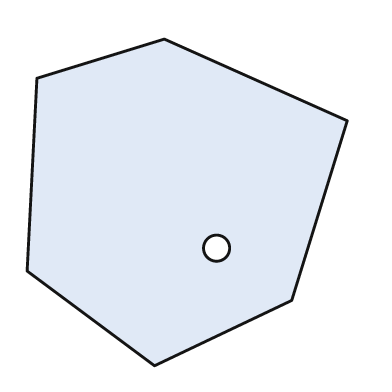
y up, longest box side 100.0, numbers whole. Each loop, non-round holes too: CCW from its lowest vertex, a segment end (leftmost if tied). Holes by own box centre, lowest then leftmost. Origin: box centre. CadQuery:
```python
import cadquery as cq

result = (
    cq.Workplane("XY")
    .moveTo(-10.0, -50.0)
    .lineTo(32.0, -30.0)
    .lineTo(49.0, 25.0)
    .lineTo(-7.0, 50.0)
    .lineTo(-46.0, 38.0)
    .lineTo(-49.0, -21.0)
    .close()
    .moveTo(9.0, -14.0)
    .circle(4.0)
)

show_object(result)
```